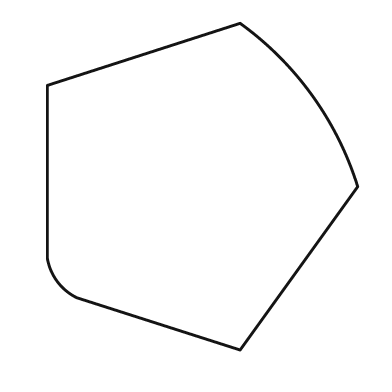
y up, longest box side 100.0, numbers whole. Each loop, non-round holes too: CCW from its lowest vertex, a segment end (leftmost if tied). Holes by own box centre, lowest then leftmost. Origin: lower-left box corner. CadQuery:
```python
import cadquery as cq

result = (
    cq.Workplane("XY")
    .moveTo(59.0, 0.0)
    .lineTo(95.0, 50.0)
    .threePointArc((81.0, 78.0), (59.0, 100.0))
    .lineTo(0.0, 81.0)
    .lineTo(0.0, 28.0)
    .threePointArc((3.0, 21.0), (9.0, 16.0))
    .close()
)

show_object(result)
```